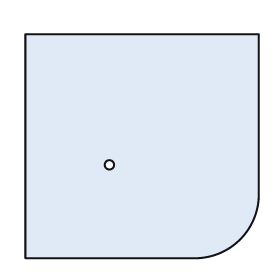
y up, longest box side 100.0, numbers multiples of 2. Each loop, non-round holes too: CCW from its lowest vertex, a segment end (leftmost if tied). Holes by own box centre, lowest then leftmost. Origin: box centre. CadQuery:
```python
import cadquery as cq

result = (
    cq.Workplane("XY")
    .moveTo(-50.0, -48.0)
    .lineTo(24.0, -48.0)
    .threePointArc((42.0, -40.0), (50.0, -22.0))
    .lineTo(50.0, 48.0)
    .lineTo(-50.0, 48.0)
    .close()
    .moveTo(-14.0, -8.0)
    .circle(2.0)
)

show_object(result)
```